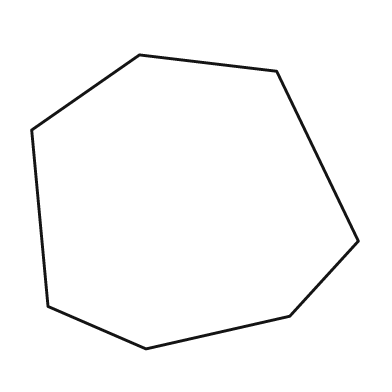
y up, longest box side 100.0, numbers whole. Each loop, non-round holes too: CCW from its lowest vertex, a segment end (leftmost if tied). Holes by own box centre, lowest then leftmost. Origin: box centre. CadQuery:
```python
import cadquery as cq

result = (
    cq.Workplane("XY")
    .moveTo(-15.0, -45.0)
    .lineTo(29.0, -35.0)
    .lineTo(50.0, -12.0)
    .lineTo(25.0, 40.0)
    .lineTo(-17.0, 45.0)
    .lineTo(-50.0, 22.0)
    .lineTo(-45.0, -32.0)
    .close()
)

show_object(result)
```